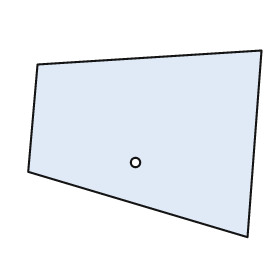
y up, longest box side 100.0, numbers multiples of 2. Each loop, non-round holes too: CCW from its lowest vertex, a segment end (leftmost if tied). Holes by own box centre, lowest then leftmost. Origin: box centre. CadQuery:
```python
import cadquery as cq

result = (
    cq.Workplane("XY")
    .moveTo(44.0, -40.0)
    .lineTo(50.0, 40.0)
    .lineTo(-46.0, 34.0)
    .lineTo(-50.0, -12.0)
    .close()
    .moveTo(-4.0, -8.0)
    .circle(2.0)
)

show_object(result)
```